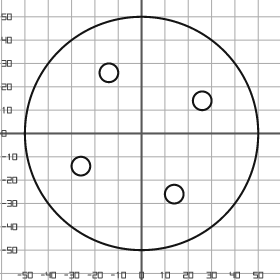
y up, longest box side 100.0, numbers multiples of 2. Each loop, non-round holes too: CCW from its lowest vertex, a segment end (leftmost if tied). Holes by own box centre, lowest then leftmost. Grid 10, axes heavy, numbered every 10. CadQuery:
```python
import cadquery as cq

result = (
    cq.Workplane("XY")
    .moveTo(0.0, 0.0)
    .circle(50.0)
    .moveTo(14.0, -26.0)
    .circle(4.0)
    .moveTo(-26.0, -14.0)
    .circle(4.0)
    .moveTo(26.0, 14.0)
    .circle(4.0)
    .moveTo(-14.0, 26.0)
    .circle(4.0)
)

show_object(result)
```